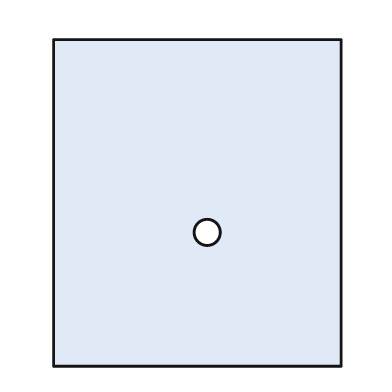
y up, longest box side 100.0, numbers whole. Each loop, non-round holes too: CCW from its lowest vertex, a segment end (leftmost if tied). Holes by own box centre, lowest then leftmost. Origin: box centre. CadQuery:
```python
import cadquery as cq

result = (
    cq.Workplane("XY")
    .moveTo(-44.0, -50.0)
    .lineTo(44.0, -50.0)
    .lineTo(44.0, 50.0)
    .lineTo(-44.0, 50.0)
    .close()
    .moveTo(3.0, -9.0)
    .circle(4.0)
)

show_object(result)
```